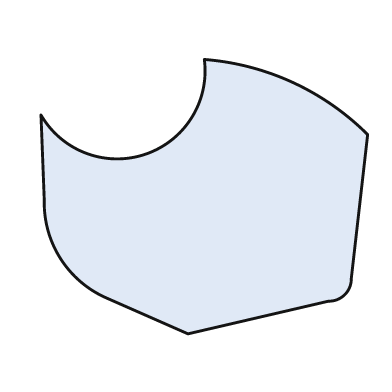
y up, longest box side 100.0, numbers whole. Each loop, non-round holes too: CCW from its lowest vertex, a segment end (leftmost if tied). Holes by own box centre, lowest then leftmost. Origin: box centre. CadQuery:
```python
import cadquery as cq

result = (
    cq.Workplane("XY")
    .moveTo(-5.0, -42.0)
    .lineTo(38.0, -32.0)
    .threePointArc((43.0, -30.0), (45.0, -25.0))
    .lineTo(50.0, 19.0)
    .threePointArc((27.0, 35.0), (0.0, 42.0))
    .threePointArc((-18.0, 13.0), (-50.0, 25.0))
    .lineTo(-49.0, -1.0)
    .threePointArc((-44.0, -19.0), (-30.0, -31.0))
    .close()
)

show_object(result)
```